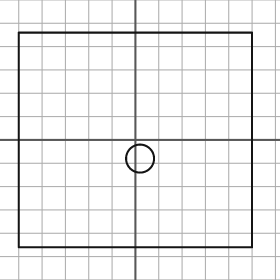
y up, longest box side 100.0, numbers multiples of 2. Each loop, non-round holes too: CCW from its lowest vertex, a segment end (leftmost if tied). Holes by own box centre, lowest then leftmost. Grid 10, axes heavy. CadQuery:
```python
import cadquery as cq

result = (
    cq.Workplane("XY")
    .moveTo(-50.0, -46.0)
    .lineTo(50.0, -46.0)
    .lineTo(50.0, 46.0)
    .lineTo(-50.0, 46.0)
    .close()
    .moveTo(2.0, -8.0)
    .circle(6.0)
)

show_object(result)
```